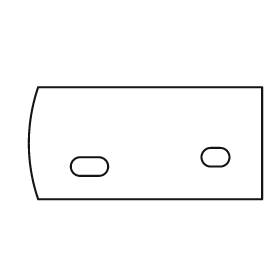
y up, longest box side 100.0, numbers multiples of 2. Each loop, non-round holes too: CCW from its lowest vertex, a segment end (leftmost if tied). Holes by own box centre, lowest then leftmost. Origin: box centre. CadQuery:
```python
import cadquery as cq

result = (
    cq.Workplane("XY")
    .moveTo(-46.0, -24.0)
    .lineTo(50.0, -24.0)
    .lineTo(50.0, 24.0)
    .lineTo(-46.0, 24.0)
    .threePointArc((-50.0, 0.0), (-46.0, -24.0))
    .close()
    .moveTo(-28.0, -14.0)
    .lineTo(-20.0, -14.0)
    .threePointArc((-16.0, -10.0), (-20.0, -6.0))
    .lineTo(-28.0, -6.0)
    .threePointArc((-32.0, -10.0), (-28.0, -14.0))
    .close()
    .moveTo(28.0, -10.0)
    .lineTo(32.0, -10.0)
    .threePointArc((36.0, -6.0), (32.0, -2.0))
    .lineTo(28.0, -2.0)
    .threePointArc((24.0, -6.0), (28.0, -10.0))
    .close()
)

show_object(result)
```